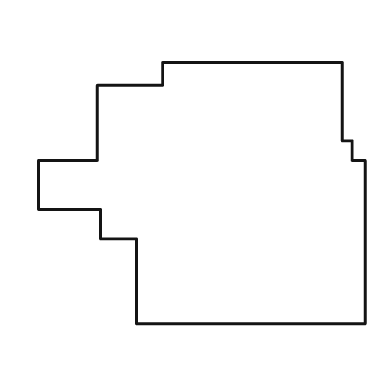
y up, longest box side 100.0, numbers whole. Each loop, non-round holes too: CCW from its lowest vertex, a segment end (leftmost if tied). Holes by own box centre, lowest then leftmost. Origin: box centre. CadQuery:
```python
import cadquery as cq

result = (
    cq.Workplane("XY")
    .moveTo(-20.0, -40.0)
    .lineTo(50.0, -40.0)
    .lineTo(50.0, 10.0)
    .lineTo(46.0, 10.0)
    .lineTo(46.0, 16.0)
    .lineTo(43.0, 16.0)
    .lineTo(43.0, 40.0)
    .lineTo(-12.0, 40.0)
    .lineTo(-12.0, 33.0)
    .lineTo(-32.0, 33.0)
    .lineTo(-32.0, 10.0)
    .lineTo(-50.0, 10.0)
    .lineTo(-50.0, -5.0)
    .lineTo(-31.0, -5.0)
    .lineTo(-31.0, -14.0)
    .lineTo(-20.0, -14.0)
    .close()
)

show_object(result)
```